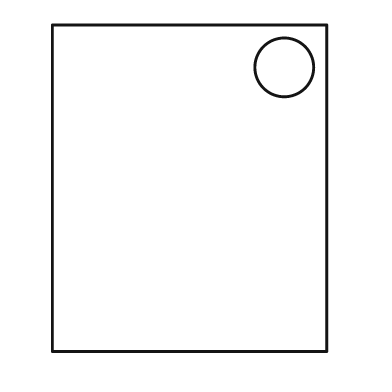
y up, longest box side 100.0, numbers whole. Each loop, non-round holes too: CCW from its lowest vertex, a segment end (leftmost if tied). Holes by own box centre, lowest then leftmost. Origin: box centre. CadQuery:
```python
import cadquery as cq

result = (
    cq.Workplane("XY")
    .moveTo(-42.0, -50.0)
    .lineTo(42.0, -50.0)
    .lineTo(42.0, 50.0)
    .lineTo(-42.0, 50.0)
    .close()
    .moveTo(29.0, 37.0)
    .circle(9.0)
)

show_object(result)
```